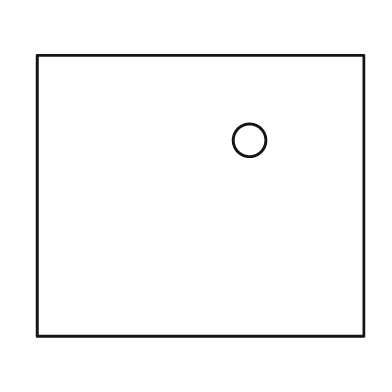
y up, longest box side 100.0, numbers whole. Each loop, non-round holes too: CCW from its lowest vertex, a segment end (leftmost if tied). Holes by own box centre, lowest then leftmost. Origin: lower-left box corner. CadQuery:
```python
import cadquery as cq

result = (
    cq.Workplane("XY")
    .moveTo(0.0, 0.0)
    .lineTo(100.0, 0.0)
    .lineTo(100.0, 86.0)
    .lineTo(0.0, 86.0)
    .close()
    .moveTo(65.0, 60.0)
    .circle(5.0)
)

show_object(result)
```